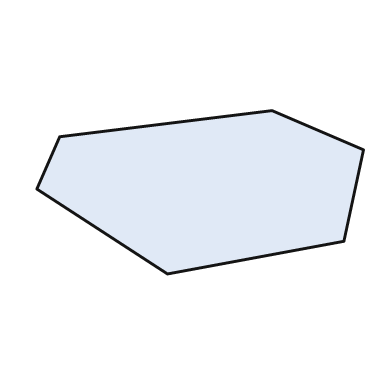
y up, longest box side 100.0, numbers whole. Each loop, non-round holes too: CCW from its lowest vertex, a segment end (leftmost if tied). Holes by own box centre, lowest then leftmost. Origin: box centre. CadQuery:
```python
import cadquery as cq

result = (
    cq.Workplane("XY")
    .moveTo(-10.0, -25.0)
    .lineTo(44.0, -15.0)
    .lineTo(50.0, 13.0)
    .lineTo(22.0, 25.0)
    .lineTo(-43.0, 17.0)
    .lineTo(-50.0, 1.0)
    .close()
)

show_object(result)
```